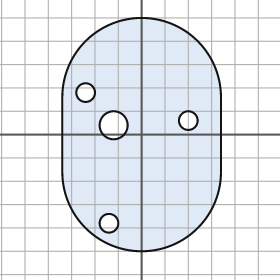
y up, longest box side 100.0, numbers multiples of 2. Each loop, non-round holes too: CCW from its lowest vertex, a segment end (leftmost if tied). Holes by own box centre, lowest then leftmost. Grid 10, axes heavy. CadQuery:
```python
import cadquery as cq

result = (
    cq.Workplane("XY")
    .moveTo(-34.0, -16.0)
    .threePointArc((0.0, -50.0), (34.0, -16.0))
    .lineTo(34.0, 16.0)
    .threePointArc((0.0, 50.0), (-34.0, 16.0))
    .close()
    .moveTo(-14.0, -38.0)
    .circle(4.0)
    .moveTo(-12.0, 4.0)
    .circle(6.0)
    .moveTo(20.0, 6.0)
    .circle(4.0)
    .moveTo(-24.0, 18.0)
    .circle(4.0)
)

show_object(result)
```